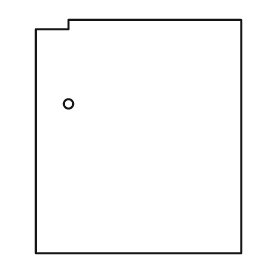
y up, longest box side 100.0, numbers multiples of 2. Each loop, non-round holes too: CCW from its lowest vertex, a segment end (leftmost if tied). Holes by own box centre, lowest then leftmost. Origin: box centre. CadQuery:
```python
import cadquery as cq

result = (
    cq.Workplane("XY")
    .moveTo(-44.0, -50.0)
    .lineTo(44.0, -50.0)
    .lineTo(44.0, 50.0)
    .lineTo(-30.0, 50.0)
    .lineTo(-30.0, 46.0)
    .lineTo(-44.0, 46.0)
    .close()
    .moveTo(-30.0, 14.0)
    .circle(2.0)
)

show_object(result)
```